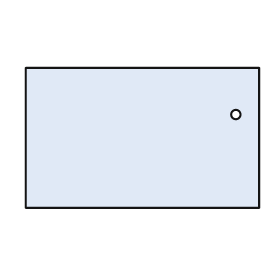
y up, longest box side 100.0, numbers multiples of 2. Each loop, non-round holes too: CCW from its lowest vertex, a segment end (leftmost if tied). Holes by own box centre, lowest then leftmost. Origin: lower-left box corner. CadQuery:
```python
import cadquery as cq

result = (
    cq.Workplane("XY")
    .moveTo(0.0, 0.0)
    .lineTo(100.0, 0.0)
    .lineTo(100.0, 60.0)
    .lineTo(0.0, 60.0)
    .close()
    .moveTo(90.0, 40.0)
    .circle(2.0)
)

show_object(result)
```